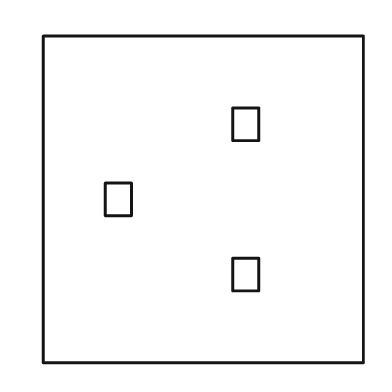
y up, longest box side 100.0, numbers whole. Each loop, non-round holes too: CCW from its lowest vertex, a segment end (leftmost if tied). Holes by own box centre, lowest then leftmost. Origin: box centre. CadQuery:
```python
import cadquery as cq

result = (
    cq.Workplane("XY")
    .moveTo(-49.0, -50.0)
    .lineTo(49.0, -50.0)
    .lineTo(49.0, 50.0)
    .lineTo(-49.0, 50.0)
    .close()
    .moveTo(9.0, -28.0)
    .lineTo(17.0, -28.0)
    .lineTo(17.0, -18.0)
    .lineTo(9.0, -18.0)
    .close()
    .moveTo(-30.0, -5.0)
    .lineTo(-22.0, -5.0)
    .lineTo(-22.0, 5.0)
    .lineTo(-30.0, 5.0)
    .close()
    .moveTo(9.0, 18.0)
    .lineTo(17.0, 18.0)
    .lineTo(17.0, 28.0)
    .lineTo(9.0, 28.0)
    .close()
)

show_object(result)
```